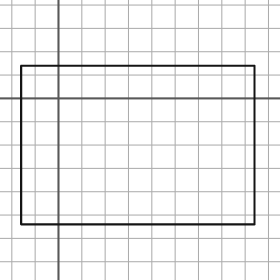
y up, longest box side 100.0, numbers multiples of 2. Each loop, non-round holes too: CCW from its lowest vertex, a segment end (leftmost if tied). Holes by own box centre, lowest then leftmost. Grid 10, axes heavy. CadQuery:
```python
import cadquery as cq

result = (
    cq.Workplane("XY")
    .moveTo(-16.0, -54.0)
    .lineTo(84.0, -54.0)
    .lineTo(84.0, 14.0)
    .lineTo(-16.0, 14.0)
    .close()
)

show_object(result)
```